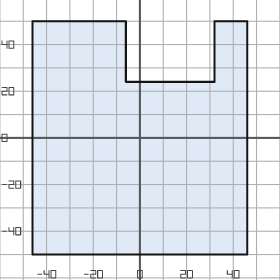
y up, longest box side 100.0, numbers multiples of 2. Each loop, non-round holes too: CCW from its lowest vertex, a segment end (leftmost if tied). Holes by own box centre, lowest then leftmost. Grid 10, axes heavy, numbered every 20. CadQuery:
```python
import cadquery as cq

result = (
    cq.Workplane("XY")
    .moveTo(-46.0, -50.0)
    .lineTo(46.0, -50.0)
    .lineTo(46.0, 50.0)
    .lineTo(32.0, 50.0)
    .lineTo(32.0, 24.0)
    .lineTo(-6.0, 24.0)
    .lineTo(-6.0, 50.0)
    .lineTo(-46.0, 50.0)
    .close()
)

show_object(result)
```